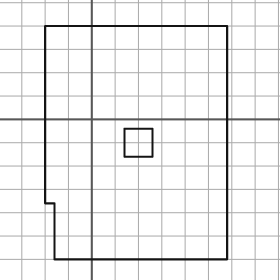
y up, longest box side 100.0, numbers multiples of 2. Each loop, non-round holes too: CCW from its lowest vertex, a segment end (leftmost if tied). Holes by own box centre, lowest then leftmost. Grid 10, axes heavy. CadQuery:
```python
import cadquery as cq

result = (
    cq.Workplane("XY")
    .moveTo(-16.0, -60.0)
    .lineTo(58.0, -60.0)
    .lineTo(58.0, 40.0)
    .lineTo(-20.0, 40.0)
    .lineTo(-20.0, -36.0)
    .lineTo(-16.0, -36.0)
    .close()
    .moveTo(14.0, -16.0)
    .lineTo(26.0, -16.0)
    .lineTo(26.0, -4.0)
    .lineTo(14.0, -4.0)
    .close()
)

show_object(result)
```